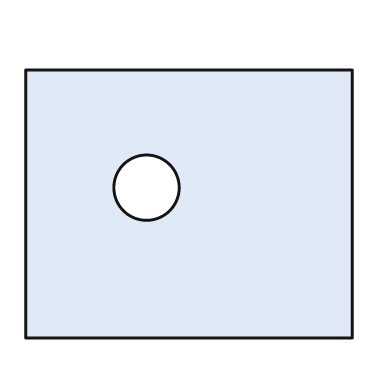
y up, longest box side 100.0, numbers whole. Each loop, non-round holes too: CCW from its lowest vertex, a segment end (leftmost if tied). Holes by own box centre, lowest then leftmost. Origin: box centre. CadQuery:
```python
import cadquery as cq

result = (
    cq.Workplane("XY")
    .moveTo(-50.0, -41.0)
    .lineTo(50.0, -41.0)
    .lineTo(50.0, 41.0)
    .lineTo(-50.0, 41.0)
    .close()
    .moveTo(-13.0, 5.0)
    .circle(10.0)
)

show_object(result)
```